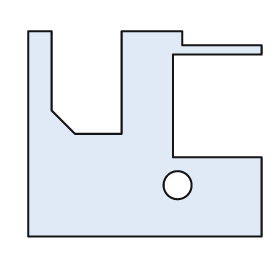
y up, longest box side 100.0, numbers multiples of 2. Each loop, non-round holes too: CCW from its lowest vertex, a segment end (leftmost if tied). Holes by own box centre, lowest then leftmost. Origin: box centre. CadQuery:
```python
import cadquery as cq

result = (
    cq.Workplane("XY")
    .moveTo(-50.0, -44.0)
    .lineTo(50.0, -44.0)
    .lineTo(50.0, -10.0)
    .lineTo(12.0, -10.0)
    .lineTo(12.0, 34.0)
    .lineTo(50.0, 34.0)
    .lineTo(50.0, 38.0)
    .lineTo(16.0, 38.0)
    .lineTo(16.0, 44.0)
    .lineTo(-10.0, 44.0)
    .lineTo(-10.0, 0.0)
    .lineTo(-30.0, 0.0)
    .lineTo(-40.0, 10.0)
    .lineTo(-40.0, 44.0)
    .lineTo(-50.0, 44.0)
    .close()
    .moveTo(14.0, -22.0)
    .circle(6.0)
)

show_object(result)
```